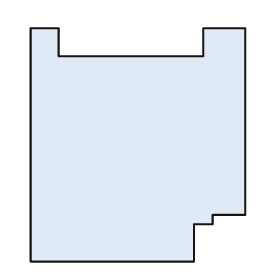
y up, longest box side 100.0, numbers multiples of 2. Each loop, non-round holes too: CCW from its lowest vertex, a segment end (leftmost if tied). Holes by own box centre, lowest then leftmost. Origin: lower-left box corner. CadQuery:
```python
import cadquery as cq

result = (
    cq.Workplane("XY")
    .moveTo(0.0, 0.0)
    .lineTo(70.0, 0.0)
    .lineTo(70.0, 16.0)
    .lineTo(78.0, 16.0)
    .lineTo(78.0, 20.0)
    .lineTo(92.0, 20.0)
    .lineTo(92.0, 100.0)
    .lineTo(74.0, 100.0)
    .lineTo(74.0, 88.0)
    .lineTo(12.0, 88.0)
    .lineTo(12.0, 100.0)
    .lineTo(0.0, 100.0)
    .close()
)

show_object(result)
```